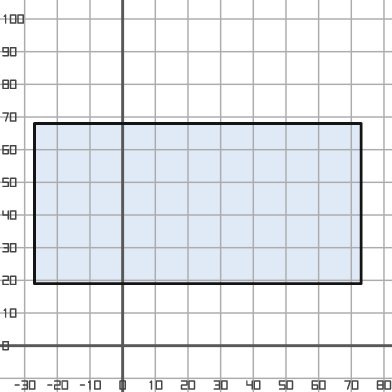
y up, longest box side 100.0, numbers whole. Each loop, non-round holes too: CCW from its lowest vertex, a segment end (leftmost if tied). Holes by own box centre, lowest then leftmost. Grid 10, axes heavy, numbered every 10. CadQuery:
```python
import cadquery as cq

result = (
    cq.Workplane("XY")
    .moveTo(-27.0, 19.0)
    .lineTo(73.0, 19.0)
    .lineTo(73.0, 68.0)
    .lineTo(-27.0, 68.0)
    .close()
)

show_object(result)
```